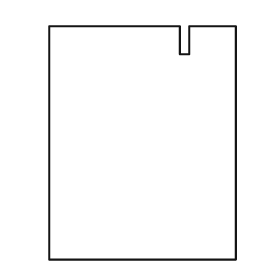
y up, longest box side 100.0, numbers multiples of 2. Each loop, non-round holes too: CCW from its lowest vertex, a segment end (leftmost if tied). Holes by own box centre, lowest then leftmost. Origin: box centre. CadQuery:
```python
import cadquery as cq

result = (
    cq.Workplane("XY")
    .moveTo(-40.0, -50.0)
    .lineTo(40.0, -50.0)
    .lineTo(40.0, 50.0)
    .lineTo(20.0, 50.0)
    .lineTo(20.0, 38.0)
    .lineTo(16.0, 38.0)
    .lineTo(16.0, 50.0)
    .lineTo(-40.0, 50.0)
    .close()
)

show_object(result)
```